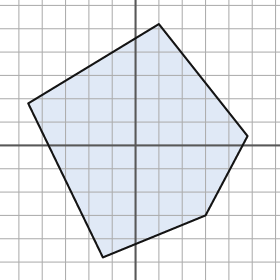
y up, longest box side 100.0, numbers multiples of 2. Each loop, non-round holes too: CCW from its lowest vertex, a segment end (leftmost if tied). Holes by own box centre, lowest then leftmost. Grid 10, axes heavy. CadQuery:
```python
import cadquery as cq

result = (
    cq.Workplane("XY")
    .moveTo(-14.0, -48.0)
    .lineTo(30.0, -30.0)
    .lineTo(48.0, 4.0)
    .lineTo(10.0, 52.0)
    .lineTo(-46.0, 18.0)
    .close()
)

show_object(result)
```